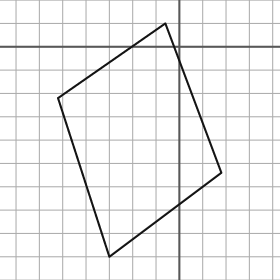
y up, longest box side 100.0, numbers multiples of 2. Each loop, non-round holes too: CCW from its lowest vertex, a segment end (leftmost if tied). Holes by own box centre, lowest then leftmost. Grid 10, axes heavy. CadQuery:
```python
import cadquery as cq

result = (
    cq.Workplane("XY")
    .moveTo(-30.0, -90.0)
    .lineTo(18.0, -54.0)
    .lineTo(-6.0, 10.0)
    .lineTo(-52.0, -22.0)
    .close()
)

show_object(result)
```